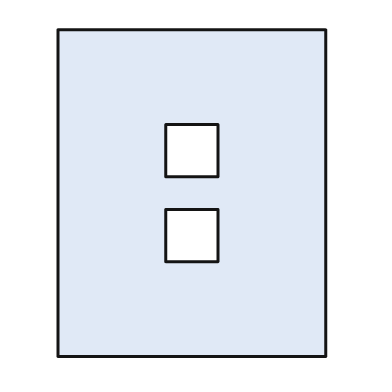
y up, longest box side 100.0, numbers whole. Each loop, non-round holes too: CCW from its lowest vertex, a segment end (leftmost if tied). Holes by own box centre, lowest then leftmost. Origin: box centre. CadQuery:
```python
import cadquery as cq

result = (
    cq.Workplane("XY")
    .moveTo(-41.0, -50.0)
    .lineTo(41.0, -50.0)
    .lineTo(41.0, 50.0)
    .lineTo(-41.0, 50.0)
    .close()
    .moveTo(-8.0, -21.0)
    .lineTo(8.0, -21.0)
    .lineTo(8.0, -5.0)
    .lineTo(-8.0, -5.0)
    .close()
    .moveTo(-8.0, 5.0)
    .lineTo(8.0, 5.0)
    .lineTo(8.0, 21.0)
    .lineTo(-8.0, 21.0)
    .close()
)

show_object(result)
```